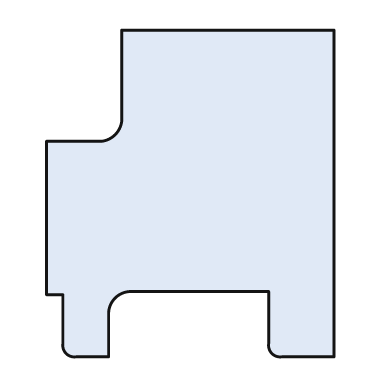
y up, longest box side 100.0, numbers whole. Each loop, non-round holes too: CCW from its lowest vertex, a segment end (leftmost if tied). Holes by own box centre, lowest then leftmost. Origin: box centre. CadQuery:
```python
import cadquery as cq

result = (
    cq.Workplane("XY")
    .moveTo(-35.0, -50.0)
    .lineTo(-25.0, -50.0)
    .lineTo(-25.0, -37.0)
    .threePointArc((-23.0, -32.0), (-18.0, -30.0))
    .lineTo(24.0, -30.0)
    .lineTo(24.0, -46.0)
    .threePointArc((25.0, -49.0), (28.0, -50.0))
    .lineTo(44.0, -50.0)
    .lineTo(44.0, 50.0)
    .lineTo(-21.0, 50.0)
    .lineTo(-21.0, 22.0)
    .threePointArc((-23.0, 18.0), (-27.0, 16.0))
    .lineTo(-44.0, 16.0)
    .lineTo(-44.0, -31.0)
    .lineTo(-39.0, -31.0)
    .lineTo(-39.0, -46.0)
    .threePointArc((-38.0, -49.0), (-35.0, -50.0))
    .close()
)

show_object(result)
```